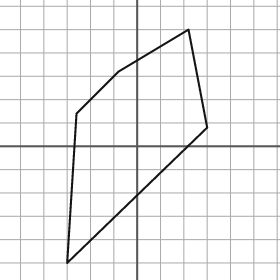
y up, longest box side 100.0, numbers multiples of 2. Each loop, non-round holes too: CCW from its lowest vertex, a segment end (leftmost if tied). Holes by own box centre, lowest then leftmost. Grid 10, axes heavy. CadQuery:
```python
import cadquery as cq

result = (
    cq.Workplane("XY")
    .moveTo(-30.0, -50.0)
    .lineTo(30.0, 8.0)
    .lineTo(22.0, 50.0)
    .lineTo(-8.0, 32.0)
    .lineTo(-26.0, 14.0)
    .close()
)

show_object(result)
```